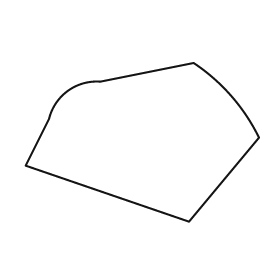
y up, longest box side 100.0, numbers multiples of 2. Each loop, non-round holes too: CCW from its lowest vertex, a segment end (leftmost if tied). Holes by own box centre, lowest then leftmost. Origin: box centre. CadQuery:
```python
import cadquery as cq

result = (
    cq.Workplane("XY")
    .moveTo(20.0, -34.0)
    .lineTo(50.0, 2.0)
    .threePointArc((38.0, 20.0), (22.0, 34.0))
    .lineTo(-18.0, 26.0)
    .threePointArc((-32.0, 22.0), (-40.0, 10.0))
    .lineTo(-50.0, -10.0)
    .close()
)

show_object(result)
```